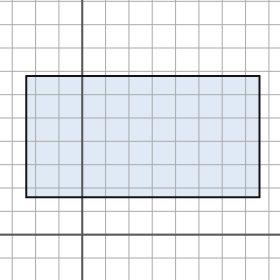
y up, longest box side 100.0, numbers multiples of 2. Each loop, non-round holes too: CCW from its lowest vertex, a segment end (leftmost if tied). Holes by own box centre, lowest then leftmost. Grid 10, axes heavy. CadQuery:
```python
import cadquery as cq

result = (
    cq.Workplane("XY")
    .moveTo(-24.0, 16.0)
    .lineTo(76.0, 16.0)
    .lineTo(76.0, 68.0)
    .lineTo(-24.0, 68.0)
    .close()
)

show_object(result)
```